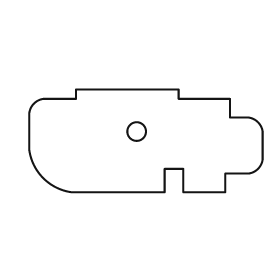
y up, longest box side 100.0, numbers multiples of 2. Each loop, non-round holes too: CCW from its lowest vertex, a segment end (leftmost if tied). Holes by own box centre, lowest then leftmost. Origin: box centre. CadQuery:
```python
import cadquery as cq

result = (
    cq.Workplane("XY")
    .moveTo(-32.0, -22.0)
    .lineTo(8.0, -22.0)
    .lineTo(8.0, -12.0)
    .lineTo(16.0, -12.0)
    .lineTo(16.0, -22.0)
    .lineTo(34.0, -22.0)
    .lineTo(34.0, -14.0)
    .lineTo(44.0, -14.0)
    .threePointArc((48.0, -12.0), (50.0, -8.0))
    .lineTo(50.0, 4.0)
    .threePointArc((48.0, 8.0), (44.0, 10.0))
    .lineTo(36.0, 10.0)
    .lineTo(36.0, 18.0)
    .lineTo(14.0, 18.0)
    .lineTo(14.0, 22.0)
    .lineTo(-30.0, 22.0)
    .lineTo(-30.0, 18.0)
    .lineTo(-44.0, 18.0)
    .threePointArc((-48.0, 16.0), (-50.0, 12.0))
    .lineTo(-50.0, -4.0)
    .threePointArc((-44.0, -16.0), (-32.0, -22.0))
    .close()
    .moveTo(-4.0, 4.0)
    .circle(4.0)
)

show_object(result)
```